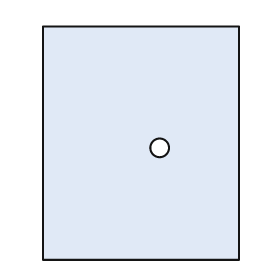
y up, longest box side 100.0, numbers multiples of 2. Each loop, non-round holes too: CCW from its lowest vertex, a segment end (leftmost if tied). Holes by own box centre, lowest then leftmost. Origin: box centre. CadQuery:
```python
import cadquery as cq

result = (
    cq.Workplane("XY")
    .moveTo(-42.0, -50.0)
    .lineTo(42.0, -50.0)
    .lineTo(42.0, 50.0)
    .lineTo(-42.0, 50.0)
    .close()
    .moveTo(8.0, -2.0)
    .circle(4.0)
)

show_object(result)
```